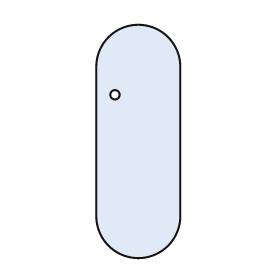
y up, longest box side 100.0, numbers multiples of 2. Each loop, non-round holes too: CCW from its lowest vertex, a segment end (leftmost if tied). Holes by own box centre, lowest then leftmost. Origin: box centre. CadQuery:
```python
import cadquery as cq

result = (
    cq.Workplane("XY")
    .moveTo(-18.0, -32.0)
    .threePointArc((0.0, -50.0), (18.0, -32.0))
    .lineTo(18.0, 32.0)
    .threePointArc((0.0, 50.0), (-18.0, 32.0))
    .close()
    .moveTo(-10.0, 20.0)
    .circle(2.0)
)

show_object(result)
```